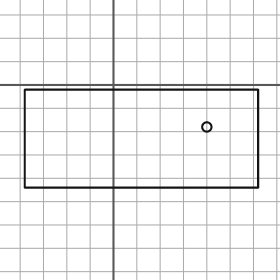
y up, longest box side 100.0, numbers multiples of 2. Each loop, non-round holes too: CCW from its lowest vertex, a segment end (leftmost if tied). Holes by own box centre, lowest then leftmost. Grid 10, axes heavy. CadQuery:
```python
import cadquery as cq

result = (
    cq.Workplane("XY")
    .moveTo(-38.0, -44.0)
    .lineTo(62.0, -44.0)
    .lineTo(62.0, -2.0)
    .lineTo(-38.0, -2.0)
    .close()
    .moveTo(40.0, -18.0)
    .circle(2.0)
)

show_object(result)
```